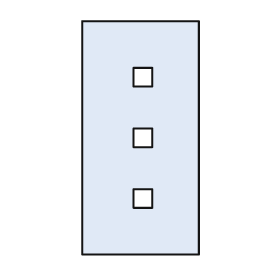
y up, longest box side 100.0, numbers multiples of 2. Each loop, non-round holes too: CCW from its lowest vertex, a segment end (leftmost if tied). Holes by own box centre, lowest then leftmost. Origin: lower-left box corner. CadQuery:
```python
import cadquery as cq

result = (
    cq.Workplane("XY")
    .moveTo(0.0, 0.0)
    .lineTo(50.0, 0.0)
    .lineTo(50.0, 100.0)
    .lineTo(0.0, 100.0)
    .close()
    .moveTo(22.0, 20.0)
    .lineTo(30.0, 20.0)
    .lineTo(30.0, 28.0)
    .lineTo(22.0, 28.0)
    .close()
    .moveTo(22.0, 46.0)
    .lineTo(30.0, 46.0)
    .lineTo(30.0, 54.0)
    .lineTo(22.0, 54.0)
    .close()
    .moveTo(22.0, 72.0)
    .lineTo(30.0, 72.0)
    .lineTo(30.0, 80.0)
    .lineTo(22.0, 80.0)
    .close()
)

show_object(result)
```